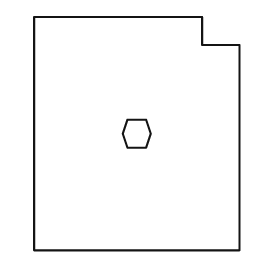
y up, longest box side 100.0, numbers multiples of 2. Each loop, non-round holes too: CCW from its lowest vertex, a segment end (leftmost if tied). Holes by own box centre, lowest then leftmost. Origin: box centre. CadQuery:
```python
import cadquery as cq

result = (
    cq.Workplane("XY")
    .moveTo(-44.0, -50.0)
    .lineTo(44.0, -50.0)
    .lineTo(44.0, 38.0)
    .lineTo(28.0, 38.0)
    .lineTo(28.0, 50.0)
    .lineTo(-44.0, 50.0)
    .close()
    .moveTo(-4.0, -6.0)
    .lineTo(4.0, -6.0)
    .lineTo(6.0, 0.0)
    .lineTo(4.0, 6.0)
    .lineTo(-4.0, 6.0)
    .lineTo(-6.0, 0.0)
    .close()
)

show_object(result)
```